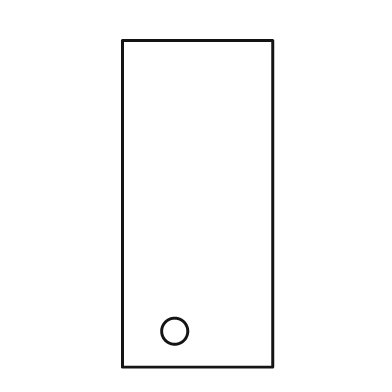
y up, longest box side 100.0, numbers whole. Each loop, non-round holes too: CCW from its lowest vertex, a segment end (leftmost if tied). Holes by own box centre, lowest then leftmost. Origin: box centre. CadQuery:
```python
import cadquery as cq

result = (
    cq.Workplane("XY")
    .moveTo(-23.0, -50.0)
    .lineTo(23.0, -50.0)
    .lineTo(23.0, 50.0)
    .lineTo(-23.0, 50.0)
    .close()
    .moveTo(-7.0, -39.0)
    .circle(4.0)
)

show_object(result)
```